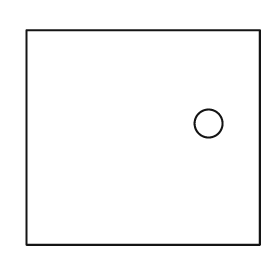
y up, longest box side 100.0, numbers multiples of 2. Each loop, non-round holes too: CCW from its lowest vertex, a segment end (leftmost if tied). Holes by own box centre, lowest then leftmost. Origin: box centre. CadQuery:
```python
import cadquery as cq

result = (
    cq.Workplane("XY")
    .moveTo(-50.0, -46.0)
    .lineTo(50.0, -46.0)
    .lineTo(50.0, 46.0)
    .lineTo(-50.0, 46.0)
    .close()
    .moveTo(28.0, 6.0)
    .circle(6.0)
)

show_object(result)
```